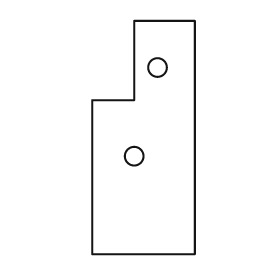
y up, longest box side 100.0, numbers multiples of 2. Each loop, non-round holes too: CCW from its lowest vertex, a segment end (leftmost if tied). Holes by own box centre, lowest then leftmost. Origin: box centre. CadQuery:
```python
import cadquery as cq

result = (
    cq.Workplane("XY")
    .moveTo(-22.0, -50.0)
    .lineTo(22.0, -50.0)
    .lineTo(22.0, 50.0)
    .lineTo(-4.0, 50.0)
    .lineTo(-4.0, 16.0)
    .lineTo(-22.0, 16.0)
    .close()
    .moveTo(-4.0, -8.0)
    .circle(4.0)
    .moveTo(6.0, 30.0)
    .circle(4.0)
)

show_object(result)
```